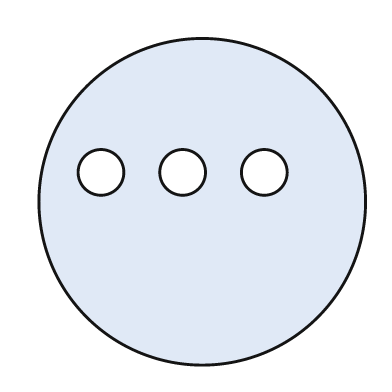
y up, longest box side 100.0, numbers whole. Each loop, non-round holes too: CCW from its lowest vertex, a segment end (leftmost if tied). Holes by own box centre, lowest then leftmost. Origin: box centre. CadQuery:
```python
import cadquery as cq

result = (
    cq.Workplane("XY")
    .moveTo(0.0, 0.0)
    .circle(50.0)
    .moveTo(-31.0, 9.0)
    .circle(7.0)
    .moveTo(-6.0, 9.0)
    .circle(7.0)
    .moveTo(19.0, 9.0)
    .circle(7.0)
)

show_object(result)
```